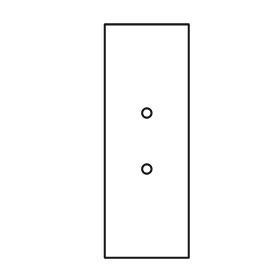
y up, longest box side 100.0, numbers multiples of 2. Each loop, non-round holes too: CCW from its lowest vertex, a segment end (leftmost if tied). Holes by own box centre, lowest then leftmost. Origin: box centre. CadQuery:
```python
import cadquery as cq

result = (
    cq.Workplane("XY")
    .moveTo(-18.0, -50.0)
    .lineTo(18.0, -50.0)
    .lineTo(18.0, 50.0)
    .lineTo(-18.0, 50.0)
    .close()
    .moveTo(0.0, -12.0)
    .circle(2.0)
    .moveTo(0.0, 12.0)
    .circle(2.0)
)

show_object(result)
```